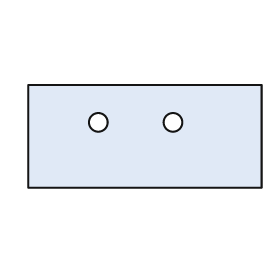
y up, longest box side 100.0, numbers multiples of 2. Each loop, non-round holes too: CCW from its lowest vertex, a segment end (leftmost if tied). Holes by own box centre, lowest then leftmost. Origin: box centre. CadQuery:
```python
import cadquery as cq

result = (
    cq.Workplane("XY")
    .moveTo(-50.0, -22.0)
    .lineTo(50.0, -22.0)
    .lineTo(50.0, 22.0)
    .lineTo(-50.0, 22.0)
    .close()
    .moveTo(-20.0, 6.0)
    .circle(4.0)
    .moveTo(12.0, 6.0)
    .circle(4.0)
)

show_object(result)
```